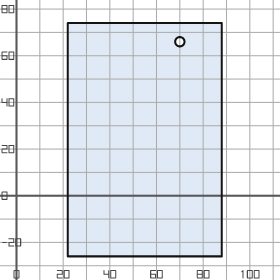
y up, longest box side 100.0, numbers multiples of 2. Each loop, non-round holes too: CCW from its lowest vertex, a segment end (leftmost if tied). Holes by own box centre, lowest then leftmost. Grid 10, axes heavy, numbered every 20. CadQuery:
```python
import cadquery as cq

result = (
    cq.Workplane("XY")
    .moveTo(22.0, -26.0)
    .lineTo(88.0, -26.0)
    .lineTo(88.0, 74.0)
    .lineTo(22.0, 74.0)
    .close()
    .moveTo(70.0, 66.0)
    .circle(2.0)
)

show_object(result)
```